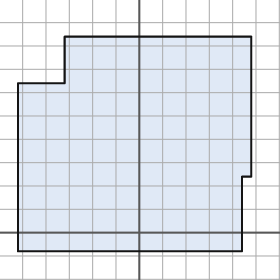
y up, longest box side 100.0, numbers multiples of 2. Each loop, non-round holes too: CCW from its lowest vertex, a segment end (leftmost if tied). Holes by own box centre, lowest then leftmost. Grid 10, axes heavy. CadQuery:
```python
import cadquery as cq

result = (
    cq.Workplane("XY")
    .moveTo(-52.0, -8.0)
    .lineTo(44.0, -8.0)
    .lineTo(44.0, 24.0)
    .lineTo(48.0, 24.0)
    .lineTo(48.0, 84.0)
    .lineTo(-32.0, 84.0)
    .lineTo(-32.0, 64.0)
    .lineTo(-52.0, 64.0)
    .close()
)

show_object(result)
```